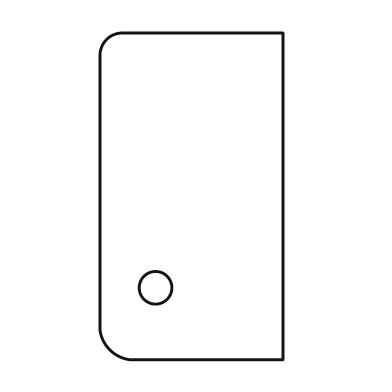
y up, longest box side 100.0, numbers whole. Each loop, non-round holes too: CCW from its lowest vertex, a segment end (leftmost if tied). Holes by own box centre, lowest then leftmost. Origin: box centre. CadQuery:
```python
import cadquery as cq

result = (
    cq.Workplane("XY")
    .moveTo(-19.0, -50.0)
    .lineTo(28.0, -50.0)
    .lineTo(28.0, 50.0)
    .lineTo(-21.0, 50.0)
    .threePointArc((-26.0, 48.0), (-28.0, 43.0))
    .lineTo(-28.0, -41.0)
    .threePointArc((-25.0, -47.0), (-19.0, -50.0))
    .close()
    .moveTo(-11.0, -28.0)
    .circle(5.0)
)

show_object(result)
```